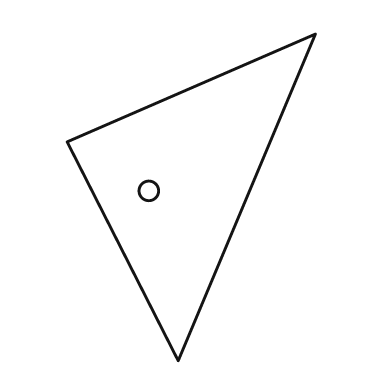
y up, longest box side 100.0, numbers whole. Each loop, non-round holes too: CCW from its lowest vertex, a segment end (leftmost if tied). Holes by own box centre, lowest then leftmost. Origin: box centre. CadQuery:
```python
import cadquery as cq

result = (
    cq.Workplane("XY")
    .moveTo(-4.0, -50.0)
    .lineTo(38.0, 50.0)
    .lineTo(-38.0, 17.0)
    .close()
    .moveTo(-13.0, 2.0)
    .circle(3.0)
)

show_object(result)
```